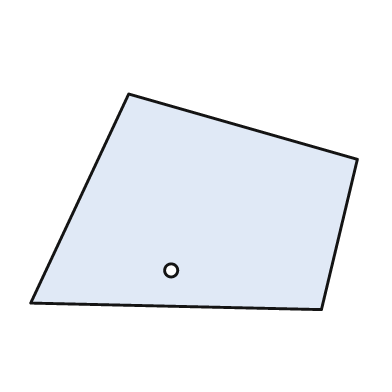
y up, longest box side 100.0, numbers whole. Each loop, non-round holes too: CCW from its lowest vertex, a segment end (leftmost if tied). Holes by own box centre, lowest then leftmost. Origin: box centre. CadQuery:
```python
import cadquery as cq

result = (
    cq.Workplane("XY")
    .moveTo(39.0, -33.0)
    .lineTo(50.0, 13.0)
    .lineTo(-20.0, 33.0)
    .lineTo(-50.0, -31.0)
    .close()
    .moveTo(-7.0, -21.0)
    .circle(2.0)
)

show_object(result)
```